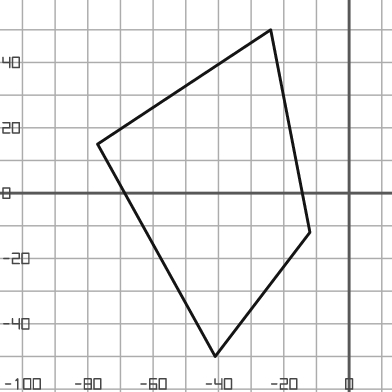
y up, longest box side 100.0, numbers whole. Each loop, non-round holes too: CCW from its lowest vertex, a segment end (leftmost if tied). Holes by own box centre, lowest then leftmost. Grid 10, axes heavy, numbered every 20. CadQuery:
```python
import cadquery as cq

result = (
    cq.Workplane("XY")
    .moveTo(-41.0, -50.0)
    .lineTo(-12.0, -12.0)
    .lineTo(-24.0, 50.0)
    .lineTo(-77.0, 15.0)
    .close()
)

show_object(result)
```